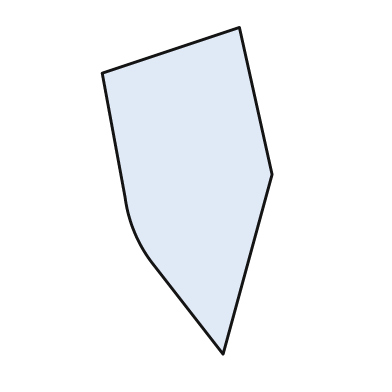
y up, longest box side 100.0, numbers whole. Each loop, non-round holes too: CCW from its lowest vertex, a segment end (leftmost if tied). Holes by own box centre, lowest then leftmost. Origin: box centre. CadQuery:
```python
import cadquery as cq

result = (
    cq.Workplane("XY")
    .moveTo(11.0, -50.0)
    .lineTo(26.0, 5.0)
    .lineTo(16.0, 50.0)
    .lineTo(-26.0, 36.0)
    .lineTo(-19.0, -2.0)
    .threePointArc((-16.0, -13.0), (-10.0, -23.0))
    .close()
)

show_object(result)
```